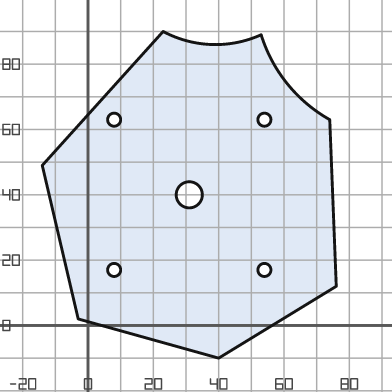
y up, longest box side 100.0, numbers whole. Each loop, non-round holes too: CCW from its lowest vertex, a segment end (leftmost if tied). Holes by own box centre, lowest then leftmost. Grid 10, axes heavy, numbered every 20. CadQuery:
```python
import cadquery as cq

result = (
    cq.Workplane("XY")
    .moveTo(40.0, -10.0)
    .lineTo(76.0, 12.0)
    .lineTo(74.0, 63.0)
    .threePointArc((61.0, 74.0), (53.0, 89.0))
    .threePointArc((38.0, 86.0), (23.0, 90.0))
    .lineTo(-14.0, 49.0)
    .lineTo(-3.0, 2.0)
    .close()
    .moveTo(8.0, 17.0)
    .circle(2.0)
    .moveTo(54.0, 17.0)
    .circle(2.0)
    .moveTo(31.0, 40.0)
    .circle(4.0)
    .moveTo(8.0, 63.0)
    .circle(2.0)
    .moveTo(54.0, 63.0)
    .circle(2.0)
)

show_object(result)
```